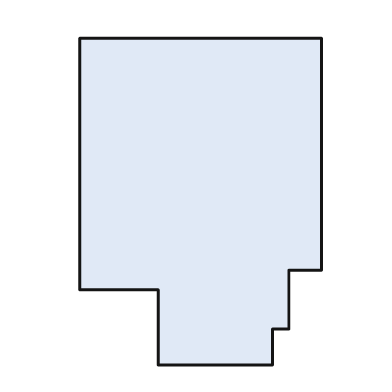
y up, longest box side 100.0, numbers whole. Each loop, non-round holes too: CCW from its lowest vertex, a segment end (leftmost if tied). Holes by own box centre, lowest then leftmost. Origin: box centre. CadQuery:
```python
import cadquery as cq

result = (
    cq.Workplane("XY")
    .moveTo(-13.0, -50.0)
    .lineTo(22.0, -50.0)
    .lineTo(22.0, -39.0)
    .lineTo(27.0, -39.0)
    .lineTo(27.0, -21.0)
    .lineTo(37.0, -21.0)
    .lineTo(37.0, 50.0)
    .lineTo(-37.0, 50.0)
    .lineTo(-37.0, -27.0)
    .lineTo(-13.0, -27.0)
    .close()
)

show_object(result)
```